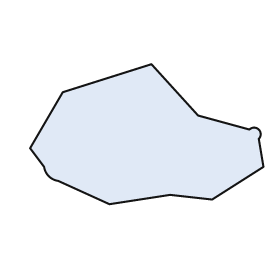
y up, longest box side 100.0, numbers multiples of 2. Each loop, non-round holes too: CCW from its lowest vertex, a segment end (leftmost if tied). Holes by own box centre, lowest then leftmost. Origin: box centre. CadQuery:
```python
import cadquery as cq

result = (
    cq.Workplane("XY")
    .moveTo(-16.0, -30.0)
    .lineTo(10.0, -26.0)
    .lineTo(28.0, -28.0)
    .lineTo(50.0, -14.0)
    .lineTo(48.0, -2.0)
    .threePointArc((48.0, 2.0), (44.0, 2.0))
    .lineTo(22.0, 8.0)
    .lineTo(2.0, 30.0)
    .lineTo(-36.0, 18.0)
    .lineTo(-50.0, -6.0)
    .lineTo(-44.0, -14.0)
    .threePointArc((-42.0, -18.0), (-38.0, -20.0))
    .close()
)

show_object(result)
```